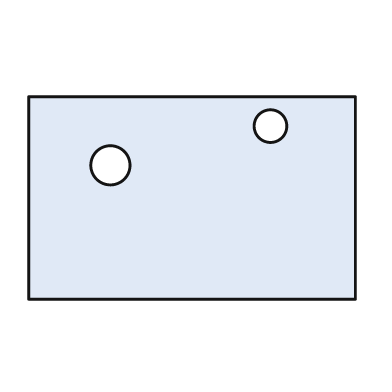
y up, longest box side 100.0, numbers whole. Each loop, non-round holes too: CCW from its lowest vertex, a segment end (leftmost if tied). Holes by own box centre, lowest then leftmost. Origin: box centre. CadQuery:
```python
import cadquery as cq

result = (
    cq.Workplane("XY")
    .moveTo(-50.0, -31.0)
    .lineTo(50.0, -31.0)
    .lineTo(50.0, 31.0)
    .lineTo(-50.0, 31.0)
    .close()
    .moveTo(-25.0, 10.0)
    .circle(6.0)
    .moveTo(24.0, 22.0)
    .circle(5.0)
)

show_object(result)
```